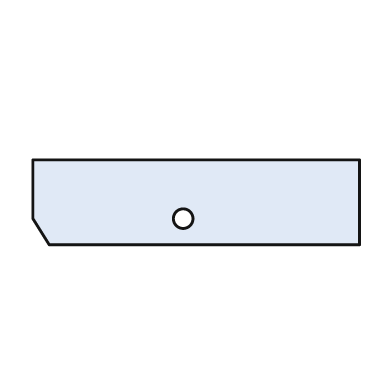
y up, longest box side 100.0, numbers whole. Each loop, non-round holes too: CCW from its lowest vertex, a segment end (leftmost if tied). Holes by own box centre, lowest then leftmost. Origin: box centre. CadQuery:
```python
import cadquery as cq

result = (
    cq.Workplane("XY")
    .moveTo(-45.0, -13.0)
    .lineTo(50.0, -13.0)
    .lineTo(50.0, 13.0)
    .lineTo(-50.0, 13.0)
    .lineTo(-50.0, -5.0)
    .close()
    .moveTo(-4.0, -5.0)
    .circle(3.0)
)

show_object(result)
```